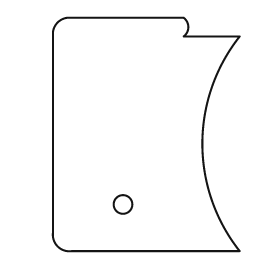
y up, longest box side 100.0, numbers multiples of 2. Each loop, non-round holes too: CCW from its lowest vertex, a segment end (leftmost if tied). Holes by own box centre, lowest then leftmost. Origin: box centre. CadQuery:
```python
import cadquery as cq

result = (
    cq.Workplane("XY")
    .moveTo(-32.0, -50.0)
    .lineTo(40.0, -50.0)
    .threePointArc((24.0, -4.0), (40.0, 42.0))
    .lineTo(16.0, 42.0)
    .threePointArc((18.0, 46.0), (16.0, 50.0))
    .lineTo(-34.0, 50.0)
    .threePointArc((-38.0, 48.0), (-40.0, 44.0))
    .lineTo(-40.0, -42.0)
    .threePointArc((-38.0, -48.0), (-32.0, -50.0))
    .close()
    .moveTo(-10.0, -30.0)
    .circle(4.0)
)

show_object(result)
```